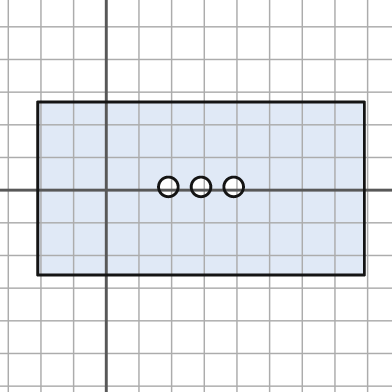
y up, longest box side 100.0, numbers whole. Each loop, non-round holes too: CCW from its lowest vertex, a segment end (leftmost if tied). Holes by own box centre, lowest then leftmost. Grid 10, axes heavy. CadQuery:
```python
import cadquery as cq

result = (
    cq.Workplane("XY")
    .moveTo(-21.0, -26.0)
    .lineTo(79.0, -26.0)
    .lineTo(79.0, 27.0)
    .lineTo(-21.0, 27.0)
    .close()
    .moveTo(19.0, 1.0)
    .circle(3.0)
    .moveTo(29.0, 1.0)
    .circle(3.0)
    .moveTo(39.0, 1.0)
    .circle(3.0)
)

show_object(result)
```